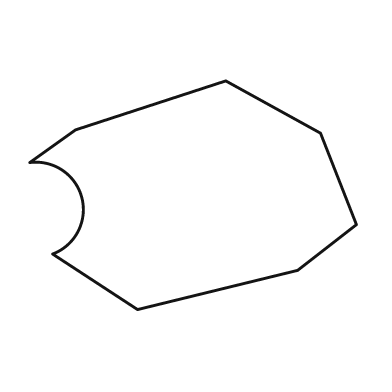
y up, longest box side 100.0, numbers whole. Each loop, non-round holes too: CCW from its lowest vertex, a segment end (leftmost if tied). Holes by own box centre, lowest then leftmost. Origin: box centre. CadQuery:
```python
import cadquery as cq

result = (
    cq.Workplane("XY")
    .moveTo(-17.0, -35.0)
    .lineTo(32.0, -23.0)
    .lineTo(50.0, -9.0)
    .lineTo(39.0, 19.0)
    .lineTo(10.0, 35.0)
    .lineTo(-36.0, 20.0)
    .lineTo(-50.0, 10.0)
    .threePointArc((-34.0, -1.0), (-43.0, -18.0))
    .close()
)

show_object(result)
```